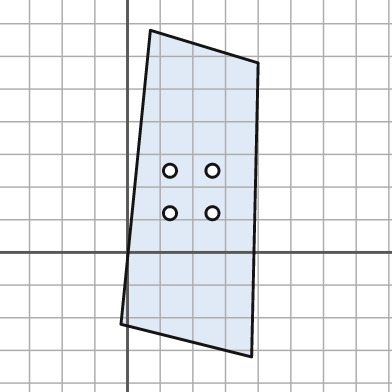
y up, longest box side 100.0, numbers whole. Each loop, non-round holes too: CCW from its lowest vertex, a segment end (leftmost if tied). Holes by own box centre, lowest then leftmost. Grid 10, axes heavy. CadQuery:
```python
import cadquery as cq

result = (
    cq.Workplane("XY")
    .moveTo(38.0, -32.0)
    .lineTo(40.0, 58.0)
    .lineTo(7.0, 68.0)
    .lineTo(-2.0, -22.0)
    .close()
    .moveTo(13.0, 12.0)
    .circle(2.0)
    .moveTo(26.0, 12.0)
    .circle(2.0)
    .moveTo(13.0, 25.0)
    .circle(2.0)
    .moveTo(26.0, 25.0)
    .circle(2.0)
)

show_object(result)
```